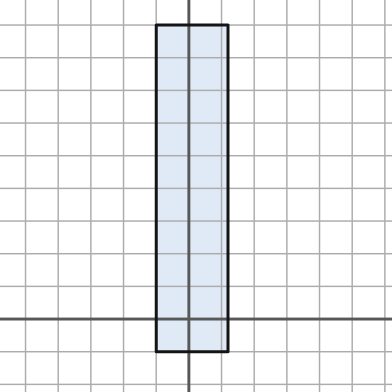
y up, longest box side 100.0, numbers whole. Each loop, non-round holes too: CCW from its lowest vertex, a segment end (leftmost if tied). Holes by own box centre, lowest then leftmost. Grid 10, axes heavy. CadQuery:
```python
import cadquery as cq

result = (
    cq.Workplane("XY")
    .moveTo(-10.0, -10.0)
    .lineTo(12.0, -10.0)
    .lineTo(12.0, 90.0)
    .lineTo(-10.0, 90.0)
    .close()
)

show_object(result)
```